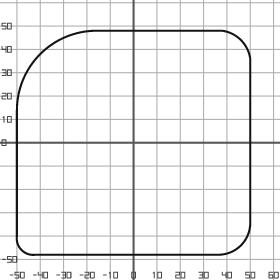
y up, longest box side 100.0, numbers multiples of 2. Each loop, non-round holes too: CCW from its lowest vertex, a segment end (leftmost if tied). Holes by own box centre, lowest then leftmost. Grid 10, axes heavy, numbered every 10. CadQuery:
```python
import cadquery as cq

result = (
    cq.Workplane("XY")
    .moveTo(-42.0, -48.0)
    .lineTo(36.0, -48.0)
    .threePointArc((46.0, -44.0), (50.0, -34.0))
    .lineTo(50.0, 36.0)
    .threePointArc((46.0, 44.0), (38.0, 48.0))
    .lineTo(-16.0, 48.0)
    .threePointArc((-40.0, 38.0), (-50.0, 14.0))
    .lineTo(-50.0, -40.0)
    .threePointArc((-48.0, -46.0), (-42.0, -48.0))
    .close()
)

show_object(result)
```